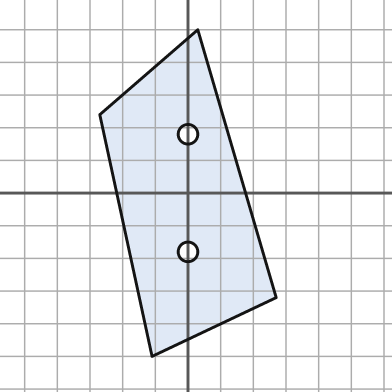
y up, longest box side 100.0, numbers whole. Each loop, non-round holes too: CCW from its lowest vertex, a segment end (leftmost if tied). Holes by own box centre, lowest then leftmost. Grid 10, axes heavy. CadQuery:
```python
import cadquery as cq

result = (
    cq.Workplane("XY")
    .moveTo(-11.0, -50.0)
    .lineTo(27.0, -32.0)
    .lineTo(3.0, 50.0)
    .lineTo(-27.0, 24.0)
    .close()
    .moveTo(0.0, -18.0)
    .circle(3.0)
    .moveTo(0.0, 18.0)
    .circle(3.0)
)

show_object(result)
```